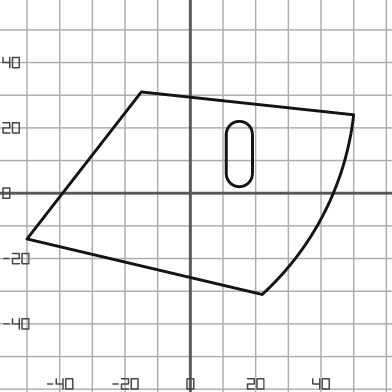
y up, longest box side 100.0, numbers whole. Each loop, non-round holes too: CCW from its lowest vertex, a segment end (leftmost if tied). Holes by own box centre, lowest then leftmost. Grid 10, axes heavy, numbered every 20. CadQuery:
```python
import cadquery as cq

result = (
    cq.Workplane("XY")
    .moveTo(22.0, -31.0)
    .threePointArc((41.0, -6.0), (50.0, 24.0))
    .lineTo(-15.0, 31.0)
    .lineTo(-50.0, -14.0)
    .close()
    .moveTo(11.0, 6.0)
    .threePointArc((15.0, 2.0), (19.0, 6.0))
    .lineTo(19.0, 18.0)
    .threePointArc((15.0, 22.0), (11.0, 18.0))
    .close()
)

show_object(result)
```